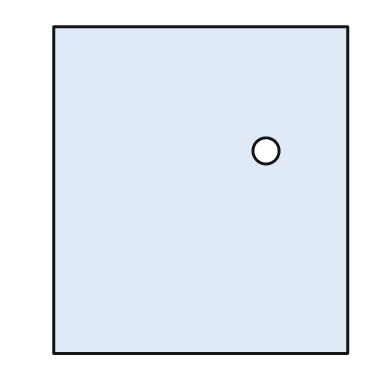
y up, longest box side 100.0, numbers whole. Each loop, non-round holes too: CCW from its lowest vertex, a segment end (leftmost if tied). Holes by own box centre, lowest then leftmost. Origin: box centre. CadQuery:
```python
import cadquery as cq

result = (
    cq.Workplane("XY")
    .moveTo(-45.0, -50.0)
    .lineTo(45.0, -50.0)
    .lineTo(45.0, 50.0)
    .lineTo(-45.0, 50.0)
    .close()
    .moveTo(20.0, 12.0)
    .circle(4.0)
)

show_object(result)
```